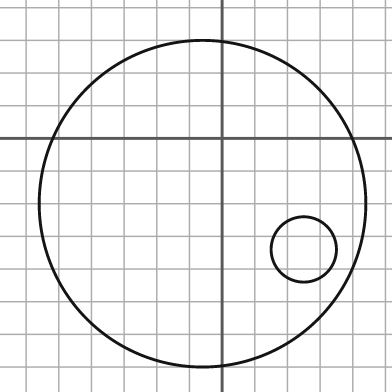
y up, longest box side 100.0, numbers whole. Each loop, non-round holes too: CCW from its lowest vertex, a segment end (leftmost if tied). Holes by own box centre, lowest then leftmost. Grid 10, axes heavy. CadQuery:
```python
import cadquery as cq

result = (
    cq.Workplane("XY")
    .moveTo(-6.0, -20.0)
    .circle(50.0)
    .moveTo(25.0, -34.0)
    .circle(10.0)
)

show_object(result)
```